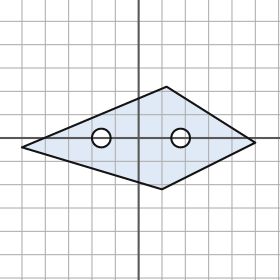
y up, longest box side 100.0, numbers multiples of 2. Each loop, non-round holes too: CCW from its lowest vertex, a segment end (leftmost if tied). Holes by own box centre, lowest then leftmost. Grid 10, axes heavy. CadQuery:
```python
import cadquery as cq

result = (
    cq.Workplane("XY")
    .moveTo(10.0, -22.0)
    .lineTo(50.0, -2.0)
    .lineTo(12.0, 22.0)
    .lineTo(-50.0, -4.0)
    .close()
    .moveTo(-16.0, 0.0)
    .circle(4.0)
    .moveTo(18.0, 0.0)
    .circle(4.0)
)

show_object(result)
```